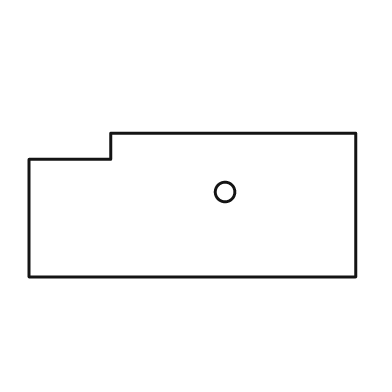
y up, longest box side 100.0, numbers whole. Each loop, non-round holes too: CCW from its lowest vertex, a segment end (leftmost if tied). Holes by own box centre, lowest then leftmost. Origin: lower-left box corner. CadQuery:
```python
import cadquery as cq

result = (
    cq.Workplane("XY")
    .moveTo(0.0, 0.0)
    .lineTo(100.0, 0.0)
    .lineTo(100.0, 44.0)
    .lineTo(25.0, 44.0)
    .lineTo(25.0, 36.0)
    .lineTo(0.0, 36.0)
    .close()
    .moveTo(60.0, 26.0)
    .circle(3.0)
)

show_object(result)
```